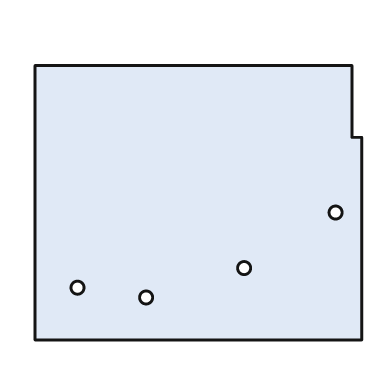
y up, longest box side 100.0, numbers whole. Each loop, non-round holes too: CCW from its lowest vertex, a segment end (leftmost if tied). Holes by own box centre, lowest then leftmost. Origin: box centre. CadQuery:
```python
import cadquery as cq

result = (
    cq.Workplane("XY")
    .moveTo(-50.0, -42.0)
    .lineTo(50.0, -42.0)
    .lineTo(50.0, 20.0)
    .lineTo(47.0, 20.0)
    .lineTo(47.0, 42.0)
    .lineTo(-50.0, 42.0)
    .close()
    .moveTo(-16.0, -29.0)
    .circle(2.0)
    .moveTo(-37.0, -26.0)
    .circle(2.0)
    .moveTo(14.0, -20.0)
    .circle(2.0)
    .moveTo(42.0, -3.0)
    .circle(2.0)
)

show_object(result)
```